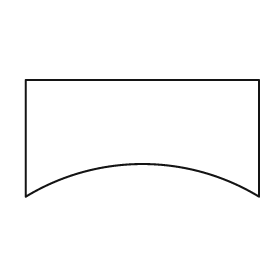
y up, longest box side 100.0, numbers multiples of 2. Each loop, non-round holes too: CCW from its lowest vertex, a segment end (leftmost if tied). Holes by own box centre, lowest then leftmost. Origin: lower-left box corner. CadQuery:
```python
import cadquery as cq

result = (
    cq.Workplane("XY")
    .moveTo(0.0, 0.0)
    .threePointArc((50.0, 14.0), (100.0, 0.0))
    .lineTo(100.0, 50.0)
    .lineTo(0.0, 50.0)
    .close()
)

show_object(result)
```